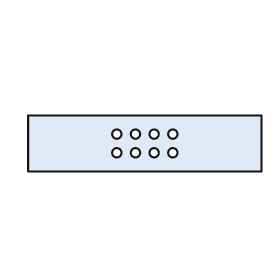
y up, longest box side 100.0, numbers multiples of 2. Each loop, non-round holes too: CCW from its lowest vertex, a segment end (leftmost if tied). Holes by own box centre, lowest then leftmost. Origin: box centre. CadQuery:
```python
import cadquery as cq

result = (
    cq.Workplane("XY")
    .moveTo(-50.0, -12.0)
    .lineTo(50.0, -12.0)
    .lineTo(50.0, 12.0)
    .lineTo(-50.0, 12.0)
    .close()
    .moveTo(-12.0, -4.0)
    .circle(2.0)
    .moveTo(-4.0, -4.0)
    .circle(2.0)
    .moveTo(4.0, -4.0)
    .circle(2.0)
    .moveTo(12.0, -4.0)
    .circle(2.0)
    .moveTo(-12.0, 4.0)
    .circle(2.0)
    .moveTo(-4.0, 4.0)
    .circle(2.0)
    .moveTo(4.0, 4.0)
    .circle(2.0)
    .moveTo(12.0, 4.0)
    .circle(2.0)
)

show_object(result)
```